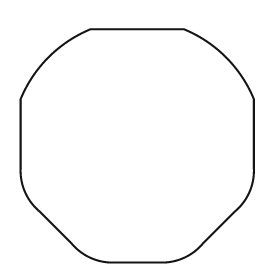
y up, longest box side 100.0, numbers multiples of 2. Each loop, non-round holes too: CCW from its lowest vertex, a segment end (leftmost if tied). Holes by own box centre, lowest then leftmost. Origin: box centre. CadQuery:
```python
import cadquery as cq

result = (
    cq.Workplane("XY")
    .moveTo(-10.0, -50.0)
    .lineTo(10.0, -50.0)
    .threePointArc((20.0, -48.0), (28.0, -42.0))
    .lineTo(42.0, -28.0)
    .threePointArc((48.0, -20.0), (50.0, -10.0))
    .lineTo(50.0, 20.0)
    .threePointArc((38.0, 38.0), (20.0, 50.0))
    .lineTo(-20.0, 50.0)
    .threePointArc((-38.0, 38.0), (-50.0, 20.0))
    .lineTo(-50.0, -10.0)
    .threePointArc((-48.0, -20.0), (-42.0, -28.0))
    .lineTo(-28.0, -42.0)
    .threePointArc((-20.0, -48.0), (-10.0, -50.0))
    .close()
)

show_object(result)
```